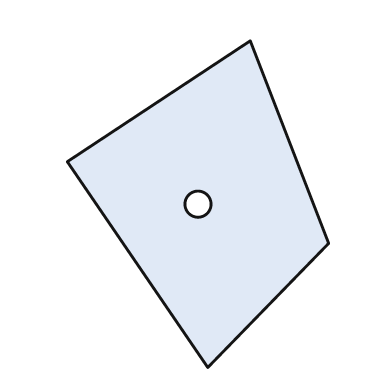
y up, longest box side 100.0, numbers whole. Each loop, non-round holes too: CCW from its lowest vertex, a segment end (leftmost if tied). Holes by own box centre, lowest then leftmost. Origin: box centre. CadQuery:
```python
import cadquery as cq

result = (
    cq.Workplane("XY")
    .moveTo(3.0, -50.0)
    .lineTo(40.0, -12.0)
    .lineTo(16.0, 50.0)
    .lineTo(-40.0, 13.0)
    .close()
    .moveTo(0.0, 0.0)
    .circle(4.0)
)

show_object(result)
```